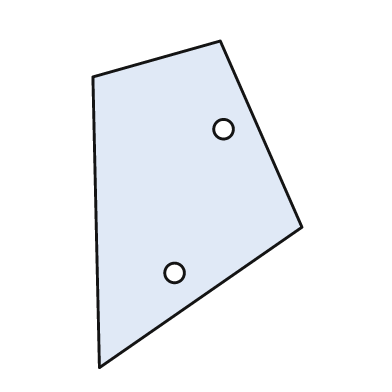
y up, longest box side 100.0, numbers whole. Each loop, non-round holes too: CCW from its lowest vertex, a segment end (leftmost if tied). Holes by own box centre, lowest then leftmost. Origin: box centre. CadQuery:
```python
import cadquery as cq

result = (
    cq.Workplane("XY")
    .moveTo(-30.0, -50.0)
    .lineTo(32.0, -7.0)
    .lineTo(7.0, 50.0)
    .lineTo(-32.0, 39.0)
    .close()
    .moveTo(-7.0, -21.0)
    .circle(3.0)
    .moveTo(8.0, 23.0)
    .circle(3.0)
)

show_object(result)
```